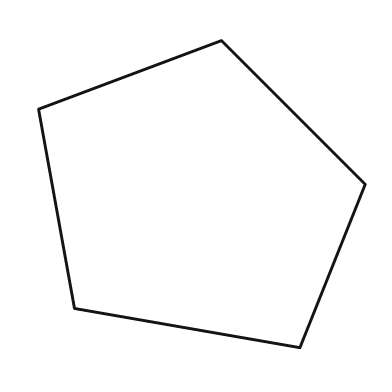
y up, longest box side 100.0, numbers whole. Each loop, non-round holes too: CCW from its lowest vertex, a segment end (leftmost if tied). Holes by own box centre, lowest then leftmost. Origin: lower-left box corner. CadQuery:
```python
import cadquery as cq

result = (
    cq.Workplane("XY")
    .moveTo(80.0, 0.0)
    .lineTo(100.0, 50.0)
    .lineTo(56.0, 94.0)
    .lineTo(0.0, 73.0)
    .lineTo(11.0, 12.0)
    .close()
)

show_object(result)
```